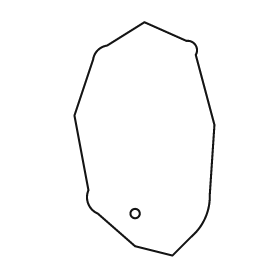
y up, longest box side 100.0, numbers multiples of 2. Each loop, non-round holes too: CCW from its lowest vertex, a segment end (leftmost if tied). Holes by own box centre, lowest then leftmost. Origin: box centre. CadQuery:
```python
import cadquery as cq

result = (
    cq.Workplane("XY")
    .moveTo(12.0, -50.0)
    .lineTo(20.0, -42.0)
    .threePointArc((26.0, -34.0), (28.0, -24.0))
    .lineTo(30.0, 6.0)
    .lineTo(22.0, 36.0)
    .threePointArc((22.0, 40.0), (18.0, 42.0))
    .lineTo(0.0, 50.0)
    .lineTo(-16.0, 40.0)
    .threePointArc((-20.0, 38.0), (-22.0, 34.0))
    .lineTo(-30.0, 10.0)
    .lineTo(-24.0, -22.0)
    .threePointArc((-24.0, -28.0), (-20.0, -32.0))
    .lineTo(-4.0, -46.0)
    .close()
    .moveTo(-4.0, -32.0)
    .circle(2.0)
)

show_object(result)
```